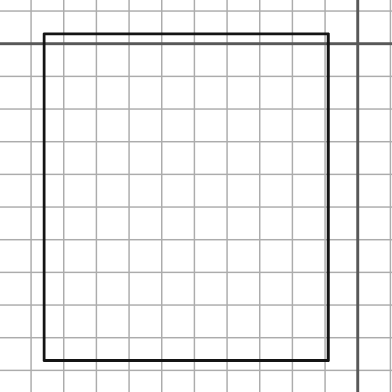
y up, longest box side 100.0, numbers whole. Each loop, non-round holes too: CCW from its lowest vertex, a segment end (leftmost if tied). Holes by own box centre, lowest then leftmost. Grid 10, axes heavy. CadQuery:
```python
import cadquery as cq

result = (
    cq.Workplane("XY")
    .moveTo(-96.0, -97.0)
    .lineTo(-9.0, -97.0)
    .lineTo(-9.0, 3.0)
    .lineTo(-96.0, 3.0)
    .close()
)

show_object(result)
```